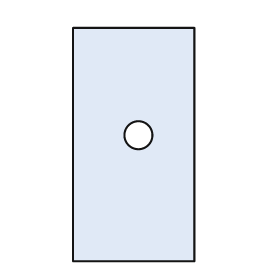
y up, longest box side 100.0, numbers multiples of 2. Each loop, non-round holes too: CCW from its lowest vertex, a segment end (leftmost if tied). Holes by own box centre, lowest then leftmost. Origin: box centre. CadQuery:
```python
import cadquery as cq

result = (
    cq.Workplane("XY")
    .moveTo(-26.0, -50.0)
    .lineTo(26.0, -50.0)
    .lineTo(26.0, 50.0)
    .lineTo(-26.0, 50.0)
    .close()
    .moveTo(2.0, 4.0)
    .circle(6.0)
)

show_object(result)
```